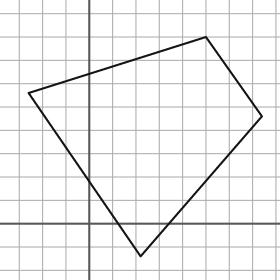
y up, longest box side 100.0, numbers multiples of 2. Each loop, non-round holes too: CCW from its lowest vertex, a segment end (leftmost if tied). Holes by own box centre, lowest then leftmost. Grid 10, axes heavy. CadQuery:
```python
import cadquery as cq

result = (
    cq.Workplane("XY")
    .moveTo(22.0, -14.0)
    .lineTo(74.0, 46.0)
    .lineTo(50.0, 80.0)
    .lineTo(-26.0, 56.0)
    .close()
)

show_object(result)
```